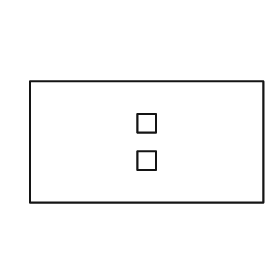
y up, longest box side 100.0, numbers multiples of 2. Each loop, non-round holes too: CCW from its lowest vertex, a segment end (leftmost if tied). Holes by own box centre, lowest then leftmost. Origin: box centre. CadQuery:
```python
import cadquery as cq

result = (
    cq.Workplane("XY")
    .moveTo(-50.0, -26.0)
    .lineTo(50.0, -26.0)
    .lineTo(50.0, 26.0)
    .lineTo(-50.0, 26.0)
    .close()
    .moveTo(-4.0, -12.0)
    .lineTo(4.0, -12.0)
    .lineTo(4.0, -4.0)
    .lineTo(-4.0, -4.0)
    .close()
    .moveTo(-4.0, 4.0)
    .lineTo(4.0, 4.0)
    .lineTo(4.0, 12.0)
    .lineTo(-4.0, 12.0)
    .close()
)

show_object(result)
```